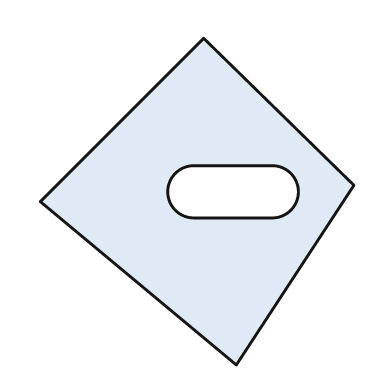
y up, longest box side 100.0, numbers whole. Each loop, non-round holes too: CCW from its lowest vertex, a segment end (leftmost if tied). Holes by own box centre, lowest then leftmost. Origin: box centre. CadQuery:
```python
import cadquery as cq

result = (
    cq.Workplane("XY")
    .moveTo(12.0, -50.0)
    .lineTo(48.0, 5.0)
    .lineTo(2.0, 50.0)
    .lineTo(-48.0, 0.0)
    .close()
    .moveTo(-1.0, -5.0)
    .lineTo(23.0, -5.0)
    .threePointArc((31.0, 3.0), (23.0, 11.0))
    .lineTo(-1.0, 11.0)
    .threePointArc((-9.0, 3.0), (-1.0, -5.0))
    .close()
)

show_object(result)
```